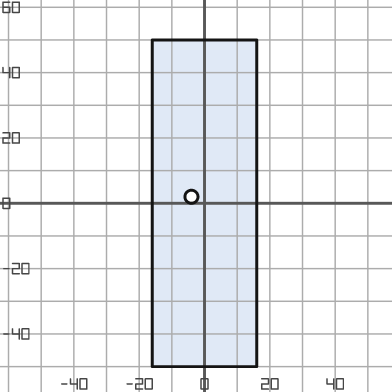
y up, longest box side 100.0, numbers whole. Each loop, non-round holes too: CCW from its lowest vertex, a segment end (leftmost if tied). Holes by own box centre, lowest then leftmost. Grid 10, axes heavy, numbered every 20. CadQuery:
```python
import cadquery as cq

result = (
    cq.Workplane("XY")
    .moveTo(-16.0, -50.0)
    .lineTo(16.0, -50.0)
    .lineTo(16.0, 50.0)
    .lineTo(-16.0, 50.0)
    .close()
    .moveTo(-4.0, 2.0)
    .circle(2.0)
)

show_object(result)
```